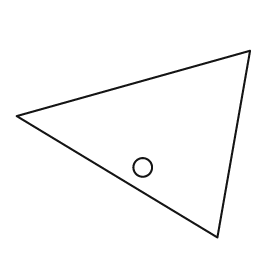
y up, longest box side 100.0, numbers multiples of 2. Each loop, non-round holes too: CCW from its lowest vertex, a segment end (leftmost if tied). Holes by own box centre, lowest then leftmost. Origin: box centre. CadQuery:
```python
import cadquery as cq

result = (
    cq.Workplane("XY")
    .moveTo(36.0, -40.0)
    .lineTo(50.0, 40.0)
    .lineTo(-50.0, 12.0)
    .close()
    .moveTo(4.0, -10.0)
    .circle(4.0)
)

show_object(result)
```